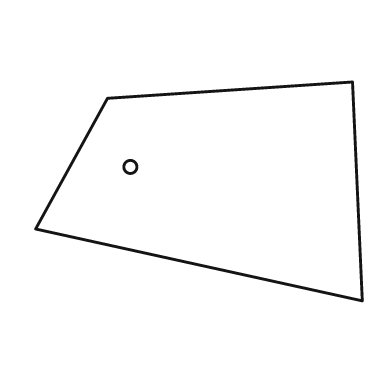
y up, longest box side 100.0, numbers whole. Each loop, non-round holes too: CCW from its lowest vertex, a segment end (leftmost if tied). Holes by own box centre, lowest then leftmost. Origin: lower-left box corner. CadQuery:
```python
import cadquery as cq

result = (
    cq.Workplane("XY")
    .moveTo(100.0, 0.0)
    .lineTo(97.0, 67.0)
    .lineTo(22.0, 62.0)
    .lineTo(0.0, 22.0)
    .close()
    .moveTo(29.0, 41.0)
    .circle(2.0)
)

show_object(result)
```